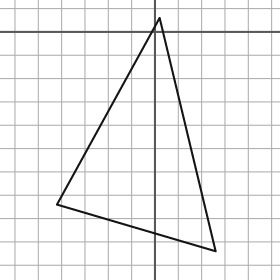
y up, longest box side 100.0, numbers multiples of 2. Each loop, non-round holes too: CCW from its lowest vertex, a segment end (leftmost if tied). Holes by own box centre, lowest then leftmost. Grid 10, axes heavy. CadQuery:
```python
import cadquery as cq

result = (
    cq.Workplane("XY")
    .moveTo(26.0, -94.0)
    .lineTo(2.0, 6.0)
    .lineTo(-42.0, -74.0)
    .close()
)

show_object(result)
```